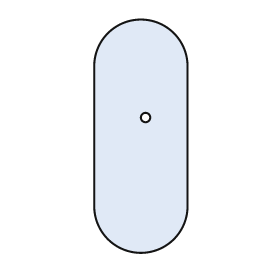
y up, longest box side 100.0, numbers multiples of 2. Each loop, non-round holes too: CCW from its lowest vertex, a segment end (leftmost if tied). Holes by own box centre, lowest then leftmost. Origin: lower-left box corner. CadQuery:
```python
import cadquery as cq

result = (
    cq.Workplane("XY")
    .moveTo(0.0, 20.0)
    .threePointArc((20.0, 0.0), (40.0, 20.0))
    .lineTo(40.0, 80.0)
    .threePointArc((20.0, 100.0), (0.0, 80.0))
    .close()
    .moveTo(22.0, 58.0)
    .circle(2.0)
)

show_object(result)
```